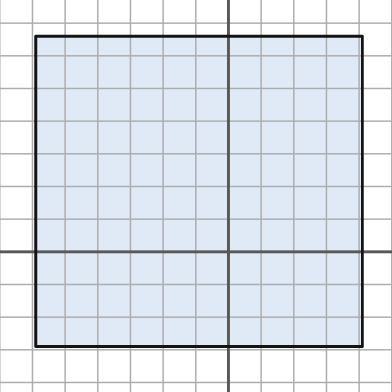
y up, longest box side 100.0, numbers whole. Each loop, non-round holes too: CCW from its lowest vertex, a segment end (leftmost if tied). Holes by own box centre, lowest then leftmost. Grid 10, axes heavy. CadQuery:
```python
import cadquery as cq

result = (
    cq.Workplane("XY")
    .moveTo(-59.0, -29.0)
    .lineTo(41.0, -29.0)
    .lineTo(41.0, 66.0)
    .lineTo(-59.0, 66.0)
    .close()
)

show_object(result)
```